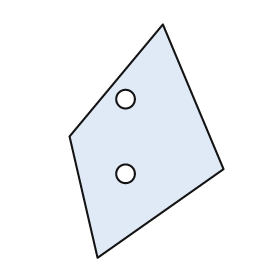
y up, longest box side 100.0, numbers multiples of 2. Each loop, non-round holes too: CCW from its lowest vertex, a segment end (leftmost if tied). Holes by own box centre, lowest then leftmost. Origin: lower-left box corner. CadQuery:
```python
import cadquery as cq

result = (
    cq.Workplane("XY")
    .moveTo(12.0, 0.0)
    .lineTo(66.0, 38.0)
    .lineTo(40.0, 100.0)
    .lineTo(0.0, 52.0)
    .close()
    .moveTo(24.0, 36.0)
    .circle(4.0)
    .moveTo(24.0, 68.0)
    .circle(4.0)
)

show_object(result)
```